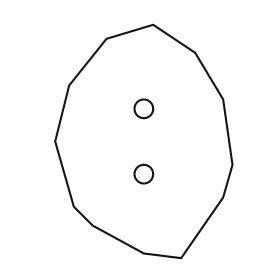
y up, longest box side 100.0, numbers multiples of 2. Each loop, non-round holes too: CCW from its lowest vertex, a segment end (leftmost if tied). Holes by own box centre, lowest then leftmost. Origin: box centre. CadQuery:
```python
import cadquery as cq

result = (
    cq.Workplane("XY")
    .moveTo(16.0, -50.0)
    .lineTo(34.0, -24.0)
    .lineTo(38.0, -10.0)
    .lineTo(34.0, 18.0)
    .lineTo(22.0, 38.0)
    .lineTo(4.0, 50.0)
    .lineTo(-16.0, 44.0)
    .lineTo(-32.0, 24.0)
    .lineTo(-38.0, 0.0)
    .lineTo(-30.0, -28.0)
    .lineTo(-22.0, -36.0)
    .lineTo(0.0, -48.0)
    .close()
    .moveTo(0.0, -14.0)
    .circle(4.0)
    .moveTo(0.0, 14.0)
    .circle(4.0)
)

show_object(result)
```